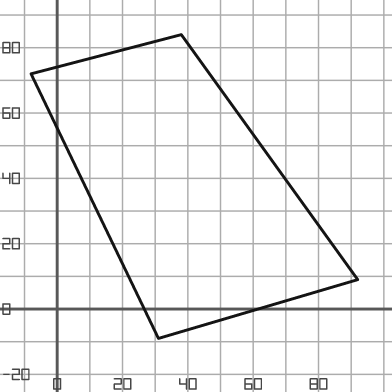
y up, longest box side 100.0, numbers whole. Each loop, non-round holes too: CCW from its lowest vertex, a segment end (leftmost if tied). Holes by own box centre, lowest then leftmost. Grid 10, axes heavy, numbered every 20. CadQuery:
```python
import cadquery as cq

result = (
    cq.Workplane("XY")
    .moveTo(31.0, -9.0)
    .lineTo(92.0, 9.0)
    .lineTo(38.0, 84.0)
    .lineTo(-8.0, 72.0)
    .close()
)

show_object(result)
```